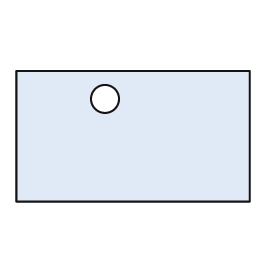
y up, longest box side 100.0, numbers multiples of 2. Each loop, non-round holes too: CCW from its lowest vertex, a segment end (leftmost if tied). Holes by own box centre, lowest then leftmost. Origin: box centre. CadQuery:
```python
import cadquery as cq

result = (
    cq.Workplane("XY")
    .moveTo(-50.0, -28.0)
    .lineTo(50.0, -28.0)
    .lineTo(50.0, 28.0)
    .lineTo(-50.0, 28.0)
    .close()
    .moveTo(-12.0, 16.0)
    .circle(6.0)
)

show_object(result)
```